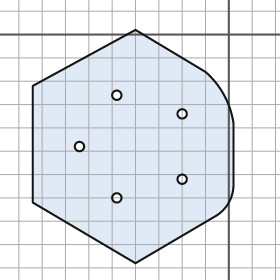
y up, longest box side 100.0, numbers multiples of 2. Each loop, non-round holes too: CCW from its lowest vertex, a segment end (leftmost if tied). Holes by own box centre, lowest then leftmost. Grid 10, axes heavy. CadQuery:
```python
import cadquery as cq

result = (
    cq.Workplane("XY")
    .moveTo(-40.0, -98.0)
    .lineTo(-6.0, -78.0)
    .threePointArc((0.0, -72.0), (2.0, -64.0))
    .lineTo(2.0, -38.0)
    .threePointArc((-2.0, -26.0), (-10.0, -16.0))
    .lineTo(-40.0, 2.0)
    .lineTo(-84.0, -22.0)
    .lineTo(-84.0, -72.0)
    .close()
    .moveTo(-48.0, -70.0)
    .circle(2.0)
    .moveTo(-20.0, -62.0)
    .circle(2.0)
    .moveTo(-64.0, -48.0)
    .circle(2.0)
    .moveTo(-20.0, -34.0)
    .circle(2.0)
    .moveTo(-48.0, -26.0)
    .circle(2.0)
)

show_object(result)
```